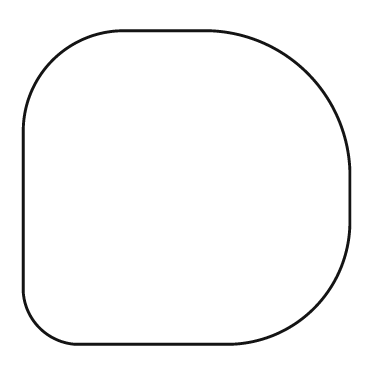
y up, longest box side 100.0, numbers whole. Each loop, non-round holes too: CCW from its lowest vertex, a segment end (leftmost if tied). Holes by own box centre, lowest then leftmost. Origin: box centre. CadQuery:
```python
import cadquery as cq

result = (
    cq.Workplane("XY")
    .moveTo(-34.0, -48.0)
    .lineTo(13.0, -48.0)
    .threePointArc((39.0, -37.0), (50.0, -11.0))
    .lineTo(50.0, 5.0)
    .threePointArc((37.0, 35.0), (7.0, 48.0))
    .lineTo(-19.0, 48.0)
    .threePointArc((-41.0, 39.0), (-50.0, 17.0))
    .lineTo(-50.0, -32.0)
    .threePointArc((-45.0, -43.0), (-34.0, -48.0))
    .close()
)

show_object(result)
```